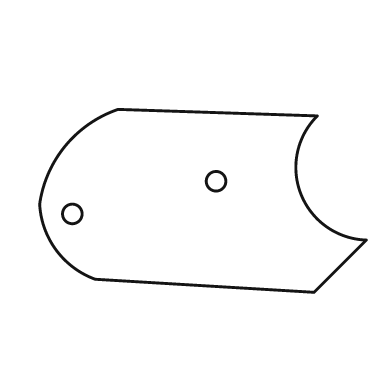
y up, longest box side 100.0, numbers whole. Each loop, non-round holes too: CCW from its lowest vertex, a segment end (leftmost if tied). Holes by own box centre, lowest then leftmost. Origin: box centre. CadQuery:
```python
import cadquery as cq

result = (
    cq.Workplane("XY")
    .moveTo(34.0, -28.0)
    .lineTo(50.0, -12.0)
    .threePointArc((30.0, 2.0), (35.0, 26.0))
    .lineTo(-26.0, 28.0)
    .threePointArc((-42.0, 17.0), (-50.0, -1.0))
    .threePointArc((-45.0, -15.0), (-33.0, -24.0))
    .close()
    .moveTo(-40.0, -4.0)
    .circle(3.0)
    .moveTo(4.0, 6.0)
    .circle(3.0)
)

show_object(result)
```